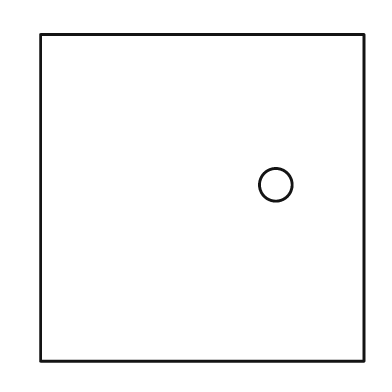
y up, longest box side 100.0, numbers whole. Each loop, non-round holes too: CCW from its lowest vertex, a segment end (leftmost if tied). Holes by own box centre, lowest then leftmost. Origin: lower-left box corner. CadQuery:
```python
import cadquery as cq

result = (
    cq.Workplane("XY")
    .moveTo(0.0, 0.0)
    .lineTo(99.0, 0.0)
    .lineTo(99.0, 100.0)
    .lineTo(0.0, 100.0)
    .close()
    .moveTo(72.0, 54.0)
    .circle(5.0)
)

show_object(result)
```